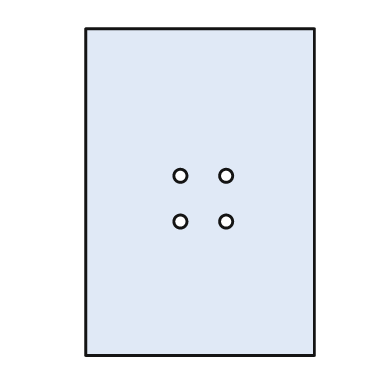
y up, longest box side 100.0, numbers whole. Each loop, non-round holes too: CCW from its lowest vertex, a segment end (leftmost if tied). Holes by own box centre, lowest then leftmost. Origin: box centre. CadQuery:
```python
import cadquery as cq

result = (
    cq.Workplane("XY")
    .moveTo(-35.0, -50.0)
    .lineTo(35.0, -50.0)
    .lineTo(35.0, 50.0)
    .lineTo(-35.0, 50.0)
    .close()
    .moveTo(-6.0, -9.0)
    .circle(2.0)
    .moveTo(8.0, -9.0)
    .circle(2.0)
    .moveTo(-6.0, 5.0)
    .circle(2.0)
    .moveTo(8.0, 5.0)
    .circle(2.0)
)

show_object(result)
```